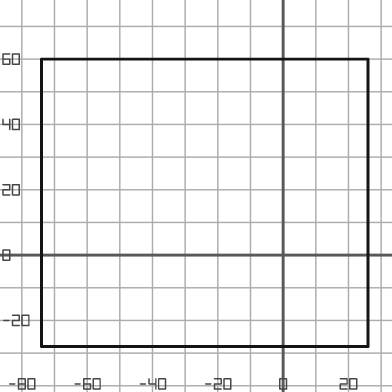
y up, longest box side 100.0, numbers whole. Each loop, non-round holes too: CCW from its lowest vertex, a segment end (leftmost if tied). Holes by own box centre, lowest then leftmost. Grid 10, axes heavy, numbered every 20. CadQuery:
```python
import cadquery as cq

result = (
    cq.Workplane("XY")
    .moveTo(-74.0, -28.0)
    .lineTo(26.0, -28.0)
    .lineTo(26.0, 60.0)
    .lineTo(-74.0, 60.0)
    .close()
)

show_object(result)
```